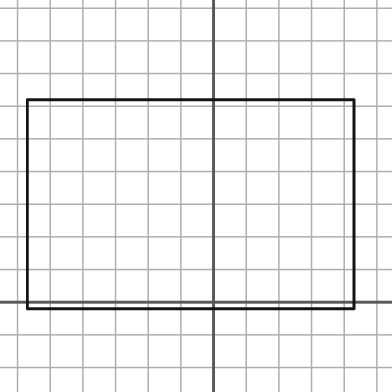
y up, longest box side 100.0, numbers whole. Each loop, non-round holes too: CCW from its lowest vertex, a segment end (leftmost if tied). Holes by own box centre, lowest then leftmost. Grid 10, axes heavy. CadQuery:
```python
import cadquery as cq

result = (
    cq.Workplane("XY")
    .moveTo(-57.0, -2.0)
    .lineTo(43.0, -2.0)
    .lineTo(43.0, 62.0)
    .lineTo(-57.0, 62.0)
    .close()
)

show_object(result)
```